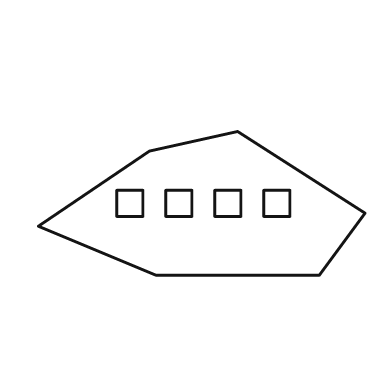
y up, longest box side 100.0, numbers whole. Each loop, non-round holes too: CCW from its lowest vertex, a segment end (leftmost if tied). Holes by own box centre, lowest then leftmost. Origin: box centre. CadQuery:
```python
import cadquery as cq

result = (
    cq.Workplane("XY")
    .moveTo(-14.0, -22.0)
    .lineTo(36.0, -22.0)
    .lineTo(50.0, -3.0)
    .lineTo(11.0, 22.0)
    .lineTo(-16.0, 16.0)
    .lineTo(-50.0, -7.0)
    .close()
    .moveTo(-26.0, -4.0)
    .lineTo(-18.0, -4.0)
    .lineTo(-18.0, 4.0)
    .lineTo(-26.0, 4.0)
    .close()
    .moveTo(-11.0, -4.0)
    .lineTo(-3.0, -4.0)
    .lineTo(-3.0, 4.0)
    .lineTo(-11.0, 4.0)
    .close()
    .moveTo(4.0, -4.0)
    .lineTo(12.0, -4.0)
    .lineTo(12.0, 4.0)
    .lineTo(4.0, 4.0)
    .close()
    .moveTo(19.0, -4.0)
    .lineTo(27.0, -4.0)
    .lineTo(27.0, 4.0)
    .lineTo(19.0, 4.0)
    .close()
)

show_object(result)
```